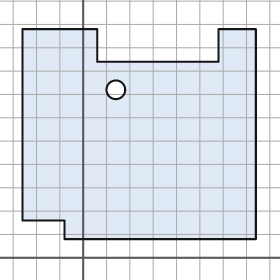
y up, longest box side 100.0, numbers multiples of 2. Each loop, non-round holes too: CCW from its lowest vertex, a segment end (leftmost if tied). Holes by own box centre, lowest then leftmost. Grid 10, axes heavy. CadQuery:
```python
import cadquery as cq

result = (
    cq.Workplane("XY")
    .moveTo(-8.0, 8.0)
    .lineTo(74.0, 8.0)
    .lineTo(74.0, 98.0)
    .lineTo(58.0, 98.0)
    .lineTo(58.0, 84.0)
    .lineTo(6.0, 84.0)
    .lineTo(6.0, 98.0)
    .lineTo(-26.0, 98.0)
    .lineTo(-26.0, 16.0)
    .lineTo(-8.0, 16.0)
    .close()
    .moveTo(14.0, 72.0)
    .circle(4.0)
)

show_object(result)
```